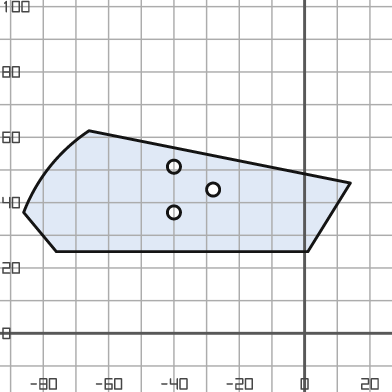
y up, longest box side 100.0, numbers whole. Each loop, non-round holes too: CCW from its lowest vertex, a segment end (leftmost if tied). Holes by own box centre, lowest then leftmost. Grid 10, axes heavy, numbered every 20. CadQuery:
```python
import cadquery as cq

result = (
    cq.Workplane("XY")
    .moveTo(-76.0, 25.0)
    .lineTo(1.0, 25.0)
    .lineTo(14.0, 46.0)
    .lineTo(-66.0, 62.0)
    .threePointArc((-78.0, 51.0), (-86.0, 37.0))
    .close()
    .moveTo(-40.0, 37.0)
    .circle(2.0)
    .moveTo(-28.0, 44.0)
    .circle(2.0)
    .moveTo(-40.0, 51.0)
    .circle(2.0)
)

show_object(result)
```